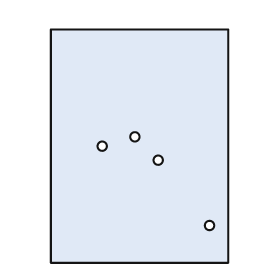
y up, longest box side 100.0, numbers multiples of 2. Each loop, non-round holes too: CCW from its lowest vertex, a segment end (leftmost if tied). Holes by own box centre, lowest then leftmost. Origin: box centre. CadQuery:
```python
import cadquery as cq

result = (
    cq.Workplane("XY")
    .moveTo(-38.0, -50.0)
    .lineTo(38.0, -50.0)
    .lineTo(38.0, 50.0)
    .lineTo(-38.0, 50.0)
    .close()
    .moveTo(30.0, -34.0)
    .circle(2.0)
    .moveTo(8.0, -6.0)
    .circle(2.0)
    .moveTo(-16.0, 0.0)
    .circle(2.0)
    .moveTo(-2.0, 4.0)
    .circle(2.0)
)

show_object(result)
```